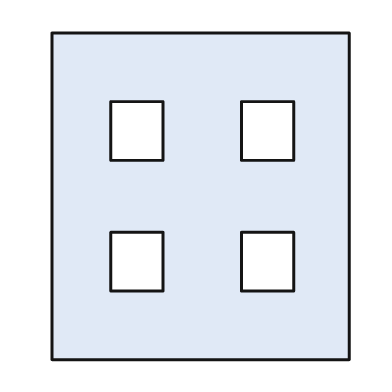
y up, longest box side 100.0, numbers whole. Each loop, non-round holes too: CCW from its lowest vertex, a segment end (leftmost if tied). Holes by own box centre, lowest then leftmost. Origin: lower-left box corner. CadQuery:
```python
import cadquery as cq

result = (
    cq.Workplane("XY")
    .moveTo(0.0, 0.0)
    .lineTo(91.0, 0.0)
    .lineTo(91.0, 100.0)
    .lineTo(0.0, 100.0)
    .close()
    .moveTo(18.0, 21.0)
    .lineTo(34.0, 21.0)
    .lineTo(34.0, 39.0)
    .lineTo(18.0, 39.0)
    .close()
    .moveTo(58.0, 21.0)
    .lineTo(74.0, 21.0)
    .lineTo(74.0, 39.0)
    .lineTo(58.0, 39.0)
    .close()
    .moveTo(18.0, 61.0)
    .lineTo(34.0, 61.0)
    .lineTo(34.0, 79.0)
    .lineTo(18.0, 79.0)
    .close()
    .moveTo(58.0, 61.0)
    .lineTo(74.0, 61.0)
    .lineTo(74.0, 79.0)
    .lineTo(58.0, 79.0)
    .close()
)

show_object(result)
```